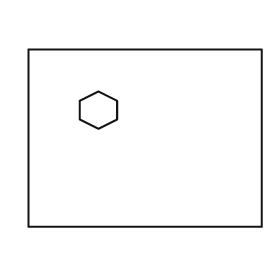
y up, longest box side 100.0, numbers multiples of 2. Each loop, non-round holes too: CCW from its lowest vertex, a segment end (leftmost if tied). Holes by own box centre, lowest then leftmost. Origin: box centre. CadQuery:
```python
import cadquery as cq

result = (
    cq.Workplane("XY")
    .moveTo(-50.0, -38.0)
    .lineTo(50.0, -38.0)
    .lineTo(50.0, 38.0)
    .lineTo(-50.0, 38.0)
    .close()
    .moveTo(-20.0, 4.0)
    .lineTo(-12.0, 8.0)
    .lineTo(-12.0, 16.0)
    .lineTo(-20.0, 20.0)
    .lineTo(-28.0, 16.0)
    .lineTo(-28.0, 8.0)
    .close()
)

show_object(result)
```